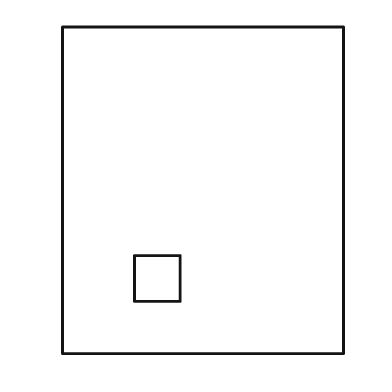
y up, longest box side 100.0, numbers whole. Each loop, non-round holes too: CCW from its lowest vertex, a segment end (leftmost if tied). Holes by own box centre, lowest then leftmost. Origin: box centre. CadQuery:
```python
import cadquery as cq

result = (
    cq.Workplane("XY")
    .moveTo(-43.0, -50.0)
    .lineTo(43.0, -50.0)
    .lineTo(43.0, 50.0)
    .lineTo(-43.0, 50.0)
    .close()
    .moveTo(-21.0, -34.0)
    .lineTo(-7.0, -34.0)
    .lineTo(-7.0, -20.0)
    .lineTo(-21.0, -20.0)
    .close()
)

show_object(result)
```